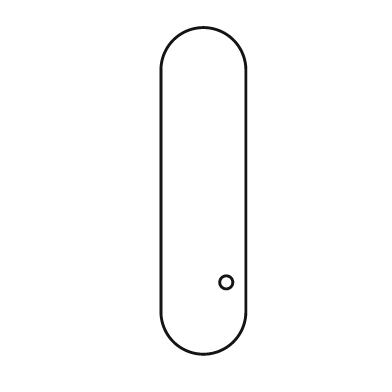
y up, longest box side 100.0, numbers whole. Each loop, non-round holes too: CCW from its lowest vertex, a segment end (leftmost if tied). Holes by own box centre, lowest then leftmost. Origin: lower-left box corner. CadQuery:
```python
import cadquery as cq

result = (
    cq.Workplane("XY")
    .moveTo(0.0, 13.0)
    .threePointArc((13.0, 0.0), (26.0, 13.0))
    .lineTo(26.0, 87.0)
    .threePointArc((13.0, 100.0), (0.0, 87.0))
    .close()
    .moveTo(20.0, 22.0)
    .circle(2.0)
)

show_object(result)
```